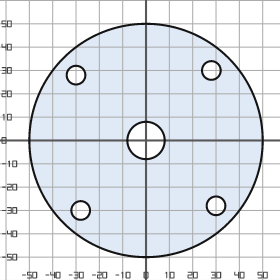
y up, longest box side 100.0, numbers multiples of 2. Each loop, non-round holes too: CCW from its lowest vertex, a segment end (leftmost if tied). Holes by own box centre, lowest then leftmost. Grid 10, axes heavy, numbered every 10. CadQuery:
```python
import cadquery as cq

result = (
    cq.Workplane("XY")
    .moveTo(0.0, 0.0)
    .circle(50.0)
    .moveTo(-28.0, -30.0)
    .circle(4.0)
    .moveTo(30.0, -28.0)
    .circle(4.0)
    .moveTo(0.0, 0.0)
    .circle(8.0)
    .moveTo(-30.0, 28.0)
    .circle(4.0)
    .moveTo(28.0, 30.0)
    .circle(4.0)
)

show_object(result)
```